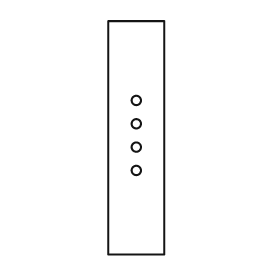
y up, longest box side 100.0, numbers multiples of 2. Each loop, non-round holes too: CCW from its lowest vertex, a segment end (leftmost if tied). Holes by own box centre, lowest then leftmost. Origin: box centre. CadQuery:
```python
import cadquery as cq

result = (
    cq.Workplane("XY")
    .moveTo(-12.0, -50.0)
    .lineTo(12.0, -50.0)
    .lineTo(12.0, 50.0)
    .lineTo(-12.0, 50.0)
    .close()
    .moveTo(0.0, -14.0)
    .circle(2.0)
    .moveTo(0.0, -4.0)
    .circle(2.0)
    .moveTo(0.0, 6.0)
    .circle(2.0)
    .moveTo(0.0, 16.0)
    .circle(2.0)
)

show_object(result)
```